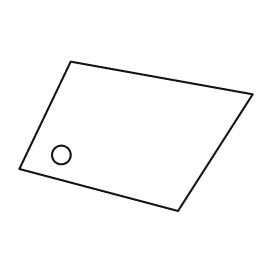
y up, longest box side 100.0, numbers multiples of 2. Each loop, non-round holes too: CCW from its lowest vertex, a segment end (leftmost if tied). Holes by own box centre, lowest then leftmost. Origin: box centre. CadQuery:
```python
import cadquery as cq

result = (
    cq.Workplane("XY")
    .moveTo(18.0, -32.0)
    .lineTo(50.0, 18.0)
    .lineTo(-28.0, 32.0)
    .lineTo(-50.0, -14.0)
    .close()
    .moveTo(-32.0, -8.0)
    .circle(4.0)
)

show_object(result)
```